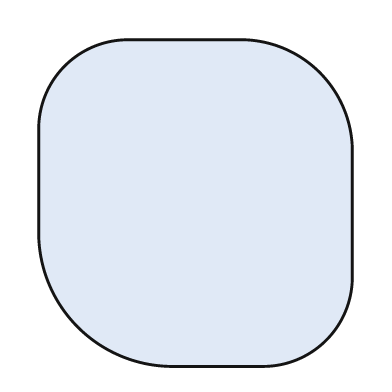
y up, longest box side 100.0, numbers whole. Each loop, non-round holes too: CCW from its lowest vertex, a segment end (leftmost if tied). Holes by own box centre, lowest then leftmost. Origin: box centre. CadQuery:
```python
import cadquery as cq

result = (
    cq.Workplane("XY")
    .moveTo(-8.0, -50.0)
    .lineTo(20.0, -50.0)
    .threePointArc((40.0, -42.0), (48.0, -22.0))
    .lineTo(48.0, 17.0)
    .threePointArc((38.0, 40.0), (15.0, 50.0))
    .lineTo(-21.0, 50.0)
    .threePointArc((-40.0, 42.0), (-48.0, 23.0))
    .lineTo(-48.0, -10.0)
    .threePointArc((-36.0, -38.0), (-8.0, -50.0))
    .close()
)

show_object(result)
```